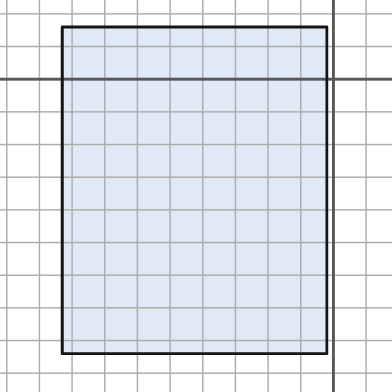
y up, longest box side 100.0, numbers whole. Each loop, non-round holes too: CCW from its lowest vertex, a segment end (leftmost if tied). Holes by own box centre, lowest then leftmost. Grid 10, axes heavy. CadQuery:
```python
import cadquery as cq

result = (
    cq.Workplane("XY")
    .moveTo(-83.0, -84.0)
    .lineTo(-2.0, -84.0)
    .lineTo(-2.0, 16.0)
    .lineTo(-83.0, 16.0)
    .close()
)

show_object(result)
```